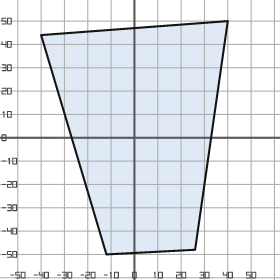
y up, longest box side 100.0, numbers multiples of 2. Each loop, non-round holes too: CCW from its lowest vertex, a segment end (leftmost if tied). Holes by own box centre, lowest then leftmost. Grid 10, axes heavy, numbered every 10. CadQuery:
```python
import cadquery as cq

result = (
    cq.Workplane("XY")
    .moveTo(-12.0, -50.0)
    .lineTo(26.0, -48.0)
    .lineTo(40.0, 50.0)
    .lineTo(-40.0, 44.0)
    .close()
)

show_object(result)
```